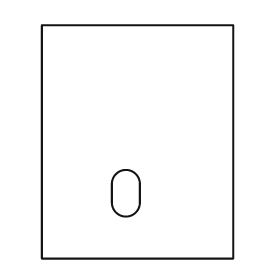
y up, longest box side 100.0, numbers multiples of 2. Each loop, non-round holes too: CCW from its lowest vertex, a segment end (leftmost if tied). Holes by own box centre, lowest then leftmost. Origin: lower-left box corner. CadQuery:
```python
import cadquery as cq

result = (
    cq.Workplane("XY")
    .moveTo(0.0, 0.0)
    .lineTo(82.0, 0.0)
    .lineTo(82.0, 100.0)
    .lineTo(0.0, 100.0)
    .close()
    .moveTo(30.0, 24.0)
    .threePointArc((36.0, 18.0), (42.0, 24.0))
    .lineTo(42.0, 32.0)
    .threePointArc((36.0, 38.0), (30.0, 32.0))
    .close()
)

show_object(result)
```